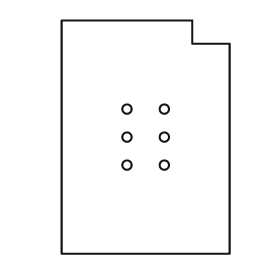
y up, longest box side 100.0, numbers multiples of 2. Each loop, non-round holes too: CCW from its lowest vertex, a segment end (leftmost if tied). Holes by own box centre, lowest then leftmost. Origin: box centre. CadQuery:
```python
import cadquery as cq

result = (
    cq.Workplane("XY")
    .moveTo(-36.0, -50.0)
    .lineTo(36.0, -50.0)
    .lineTo(36.0, 40.0)
    .lineTo(20.0, 40.0)
    .lineTo(20.0, 50.0)
    .lineTo(-36.0, 50.0)
    .close()
    .moveTo(-8.0, -12.0)
    .circle(2.0)
    .moveTo(8.0, -12.0)
    .circle(2.0)
    .moveTo(-8.0, 0.0)
    .circle(2.0)
    .moveTo(8.0, 0.0)
    .circle(2.0)
    .moveTo(-8.0, 12.0)
    .circle(2.0)
    .moveTo(8.0, 12.0)
    .circle(2.0)
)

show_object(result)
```